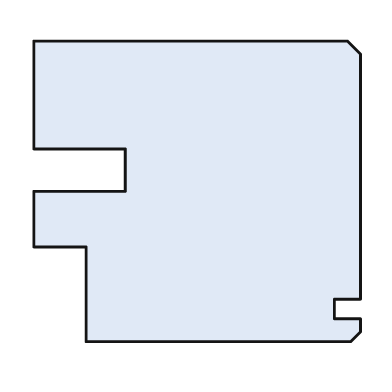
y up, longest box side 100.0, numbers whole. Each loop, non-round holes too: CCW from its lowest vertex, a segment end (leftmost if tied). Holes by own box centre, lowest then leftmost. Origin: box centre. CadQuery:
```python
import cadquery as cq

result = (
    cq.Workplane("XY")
    .moveTo(-34.0, -46.0)
    .lineTo(47.0, -46.0)
    .lineTo(50.0, -43.0)
    .lineTo(50.0, -39.0)
    .lineTo(42.0, -39.0)
    .lineTo(42.0, -33.0)
    .lineTo(50.0, -33.0)
    .lineTo(50.0, 42.0)
    .lineTo(46.0, 46.0)
    .lineTo(-50.0, 46.0)
    .lineTo(-50.0, 13.0)
    .lineTo(-22.0, 13.0)
    .lineTo(-22.0, 0.0)
    .lineTo(-50.0, 0.0)
    .lineTo(-50.0, -17.0)
    .lineTo(-34.0, -17.0)
    .close()
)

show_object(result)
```